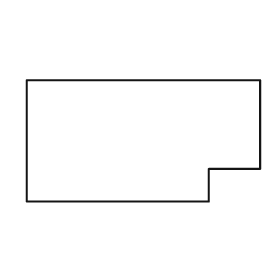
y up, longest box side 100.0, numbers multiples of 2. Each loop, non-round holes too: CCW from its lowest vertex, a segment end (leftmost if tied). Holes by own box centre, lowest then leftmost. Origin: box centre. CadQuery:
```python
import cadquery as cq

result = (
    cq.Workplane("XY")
    .moveTo(-50.0, -26.0)
    .lineTo(28.0, -26.0)
    .lineTo(28.0, -12.0)
    .lineTo(50.0, -12.0)
    .lineTo(50.0, 26.0)
    .lineTo(-50.0, 26.0)
    .close()
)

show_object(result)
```